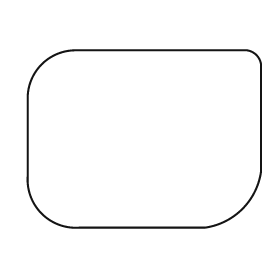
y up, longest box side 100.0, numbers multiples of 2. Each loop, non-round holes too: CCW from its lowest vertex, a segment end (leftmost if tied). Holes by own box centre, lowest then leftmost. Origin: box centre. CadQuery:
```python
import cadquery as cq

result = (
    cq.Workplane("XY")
    .moveTo(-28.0, -38.0)
    .lineTo(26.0, -38.0)
    .threePointArc((42.0, -30.0), (50.0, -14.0))
    .lineTo(50.0, 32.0)
    .threePointArc((48.0, 36.0), (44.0, 38.0))
    .lineTo(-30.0, 38.0)
    .threePointArc((-44.0, 32.0), (-50.0, 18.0))
    .lineTo(-50.0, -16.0)
    .threePointArc((-44.0, -32.0), (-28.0, -38.0))
    .close()
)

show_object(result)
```